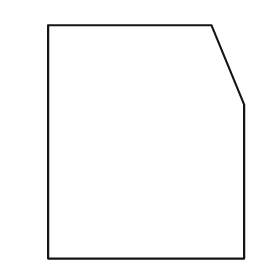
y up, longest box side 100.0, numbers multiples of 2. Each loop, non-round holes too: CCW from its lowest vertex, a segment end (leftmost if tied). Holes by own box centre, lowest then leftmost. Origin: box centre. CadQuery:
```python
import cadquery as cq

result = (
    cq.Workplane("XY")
    .moveTo(-42.0, -50.0)
    .lineTo(42.0, -50.0)
    .lineTo(42.0, 16.0)
    .lineTo(28.0, 50.0)
    .lineTo(-42.0, 50.0)
    .close()
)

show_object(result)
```